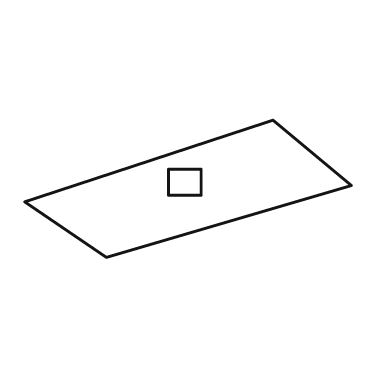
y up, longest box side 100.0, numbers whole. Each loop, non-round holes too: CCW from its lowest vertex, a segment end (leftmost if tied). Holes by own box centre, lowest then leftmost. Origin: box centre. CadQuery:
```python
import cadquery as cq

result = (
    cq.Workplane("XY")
    .moveTo(-25.0, -21.0)
    .lineTo(50.0, 1.0)
    .lineTo(26.0, 21.0)
    .lineTo(-50.0, -4.0)
    .close()
    .moveTo(-6.0, -2.0)
    .lineTo(4.0, -2.0)
    .lineTo(4.0, 6.0)
    .lineTo(-6.0, 6.0)
    .close()
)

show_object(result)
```